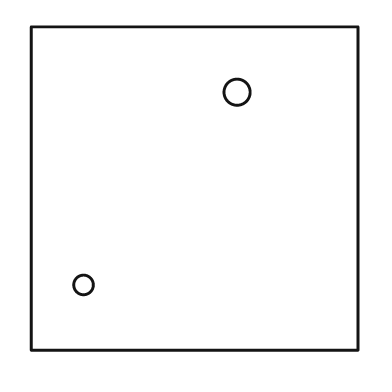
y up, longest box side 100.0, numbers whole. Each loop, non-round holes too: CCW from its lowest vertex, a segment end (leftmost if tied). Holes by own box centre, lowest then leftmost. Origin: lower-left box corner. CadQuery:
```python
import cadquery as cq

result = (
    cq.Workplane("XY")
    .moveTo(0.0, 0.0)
    .lineTo(100.0, 0.0)
    .lineTo(100.0, 99.0)
    .lineTo(0.0, 99.0)
    .close()
    .moveTo(16.0, 20.0)
    .circle(3.0)
    .moveTo(63.0, 79.0)
    .circle(4.0)
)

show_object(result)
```